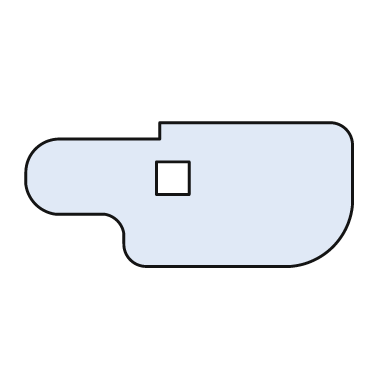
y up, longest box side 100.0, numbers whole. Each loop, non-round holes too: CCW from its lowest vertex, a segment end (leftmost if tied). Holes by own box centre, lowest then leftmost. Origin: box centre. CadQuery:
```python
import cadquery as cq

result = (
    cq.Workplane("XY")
    .moveTo(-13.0, -22.0)
    .lineTo(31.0, -22.0)
    .threePointArc((44.0, -16.0), (50.0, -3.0))
    .lineTo(50.0, 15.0)
    .threePointArc((48.0, 20.0), (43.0, 22.0))
    .lineTo(-9.0, 22.0)
    .lineTo(-9.0, 17.0)
    .lineTo(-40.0, 17.0)
    .threePointArc((-47.0, 14.0), (-50.0, 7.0))
    .lineTo(-50.0, 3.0)
    .threePointArc((-47.0, -3.0), (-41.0, -6.0))
    .lineTo(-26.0, -6.0)
    .threePointArc((-22.0, -8.0), (-20.0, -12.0))
    .lineTo(-20.0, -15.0)
    .threePointArc((-18.0, -20.0), (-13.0, -22.0))
    .close()
    .moveTo(-10.0, 0.0)
    .lineTo(0.0, 0.0)
    .lineTo(0.0, 10.0)
    .lineTo(-10.0, 10.0)
    .close()
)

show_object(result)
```